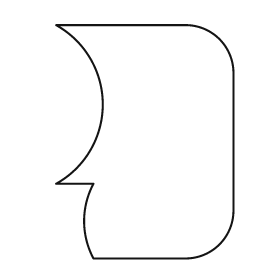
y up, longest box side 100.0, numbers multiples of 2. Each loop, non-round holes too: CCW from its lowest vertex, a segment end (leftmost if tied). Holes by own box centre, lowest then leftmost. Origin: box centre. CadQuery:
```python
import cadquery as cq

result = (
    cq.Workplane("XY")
    .moveTo(-22.0, -50.0)
    .lineTo(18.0, -50.0)
    .threePointArc((32.0, -44.0), (38.0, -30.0))
    .lineTo(38.0, 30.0)
    .threePointArc((32.0, 44.0), (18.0, 50.0))
    .lineTo(-38.0, 50.0)
    .threePointArc((-18.0, 16.0), (-38.0, -18.0))
    .lineTo(-22.0, -18.0)
    .threePointArc((-26.0, -34.0), (-22.0, -50.0))
    .close()
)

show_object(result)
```